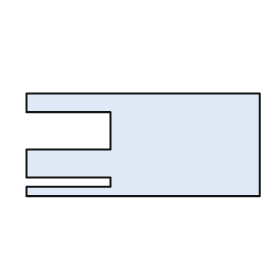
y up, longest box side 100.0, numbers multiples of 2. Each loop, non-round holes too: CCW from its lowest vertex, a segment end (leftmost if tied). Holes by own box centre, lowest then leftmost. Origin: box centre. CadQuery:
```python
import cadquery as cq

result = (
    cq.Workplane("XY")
    .moveTo(-50.0, -22.0)
    .lineTo(50.0, -22.0)
    .lineTo(50.0, 22.0)
    .lineTo(-50.0, 22.0)
    .lineTo(-50.0, 14.0)
    .lineTo(-14.0, 14.0)
    .lineTo(-14.0, -2.0)
    .lineTo(-50.0, -2.0)
    .lineTo(-50.0, -14.0)
    .lineTo(-14.0, -14.0)
    .lineTo(-14.0, -18.0)
    .lineTo(-50.0, -18.0)
    .close()
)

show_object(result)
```